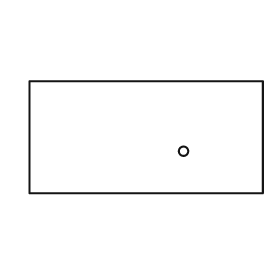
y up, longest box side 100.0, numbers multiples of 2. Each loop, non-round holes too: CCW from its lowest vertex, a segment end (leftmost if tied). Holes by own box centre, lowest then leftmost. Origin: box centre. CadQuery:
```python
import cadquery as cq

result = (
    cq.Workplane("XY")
    .moveTo(-50.0, -24.0)
    .lineTo(50.0, -24.0)
    .lineTo(50.0, 24.0)
    .lineTo(-50.0, 24.0)
    .close()
    .moveTo(16.0, -6.0)
    .circle(2.0)
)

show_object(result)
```